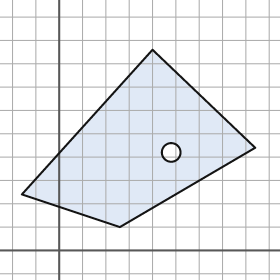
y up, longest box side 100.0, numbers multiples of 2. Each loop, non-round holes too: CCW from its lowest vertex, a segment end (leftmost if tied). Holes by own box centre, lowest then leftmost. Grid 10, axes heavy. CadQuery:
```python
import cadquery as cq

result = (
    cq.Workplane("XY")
    .moveTo(26.0, 10.0)
    .lineTo(84.0, 44.0)
    .lineTo(40.0, 86.0)
    .lineTo(-16.0, 24.0)
    .close()
    .moveTo(48.0, 42.0)
    .circle(4.0)
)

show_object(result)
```